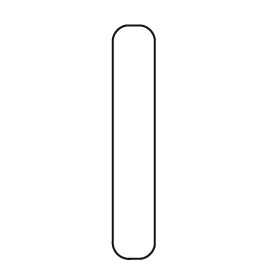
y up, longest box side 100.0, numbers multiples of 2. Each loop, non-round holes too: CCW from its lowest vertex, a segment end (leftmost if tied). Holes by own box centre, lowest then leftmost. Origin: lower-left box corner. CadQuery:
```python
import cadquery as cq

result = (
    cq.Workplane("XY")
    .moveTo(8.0, 0.0)
    .lineTo(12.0, 0.0)
    .threePointArc((16.0, 2.0), (18.0, 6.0))
    .lineTo(18.0, 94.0)
    .threePointArc((16.0, 98.0), (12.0, 100.0))
    .lineTo(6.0, 100.0)
    .threePointArc((2.0, 98.0), (0.0, 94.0))
    .lineTo(0.0, 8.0)
    .threePointArc((2.0, 2.0), (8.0, 0.0))
    .close()
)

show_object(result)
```